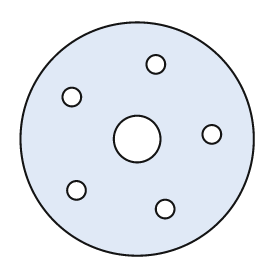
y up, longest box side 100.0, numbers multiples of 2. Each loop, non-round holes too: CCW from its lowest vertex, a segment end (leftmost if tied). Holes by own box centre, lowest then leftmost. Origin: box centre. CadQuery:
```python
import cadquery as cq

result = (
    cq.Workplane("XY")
    .moveTo(0.0, 0.0)
    .circle(50.0)
    .moveTo(12.0, -30.0)
    .circle(4.0)
    .moveTo(-26.0, -22.0)
    .circle(4.0)
    .moveTo(0.0, 0.0)
    .circle(10.0)
    .moveTo(32.0, 2.0)
    .circle(4.0)
    .moveTo(-28.0, 18.0)
    .circle(4.0)
    .moveTo(8.0, 32.0)
    .circle(4.0)
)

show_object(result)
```